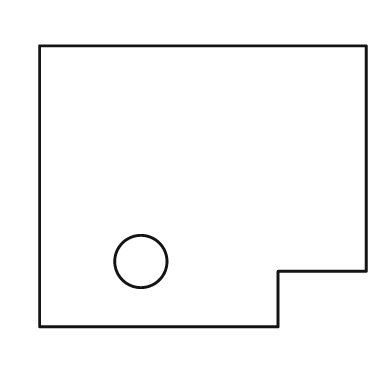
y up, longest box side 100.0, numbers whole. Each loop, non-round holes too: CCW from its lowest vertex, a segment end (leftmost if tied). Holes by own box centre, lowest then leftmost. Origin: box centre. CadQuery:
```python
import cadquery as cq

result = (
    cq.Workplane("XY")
    .moveTo(-50.0, -43.0)
    .lineTo(23.0, -43.0)
    .lineTo(23.0, -26.0)
    .lineTo(50.0, -26.0)
    .lineTo(50.0, 43.0)
    .lineTo(-50.0, 43.0)
    .close()
    .moveTo(-19.0, -23.0)
    .circle(8.0)
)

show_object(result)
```